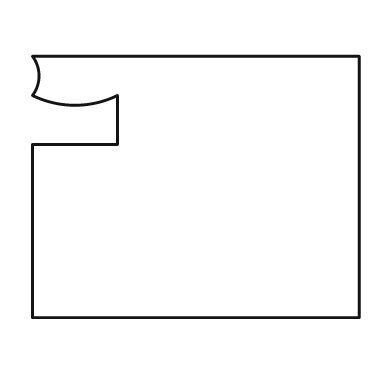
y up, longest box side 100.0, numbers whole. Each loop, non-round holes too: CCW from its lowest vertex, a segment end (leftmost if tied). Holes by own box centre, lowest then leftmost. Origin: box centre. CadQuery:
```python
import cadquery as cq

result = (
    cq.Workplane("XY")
    .moveTo(-50.0, -40.0)
    .lineTo(50.0, -40.0)
    .lineTo(50.0, 40.0)
    .lineTo(-50.0, 40.0)
    .threePointArc((-48.0, 34.0), (-50.0, 28.0))
    .threePointArc((-37.0, 25.0), (-24.0, 28.0))
    .lineTo(-24.0, 13.0)
    .lineTo(-50.0, 13.0)
    .close()
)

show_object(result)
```